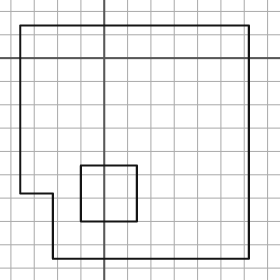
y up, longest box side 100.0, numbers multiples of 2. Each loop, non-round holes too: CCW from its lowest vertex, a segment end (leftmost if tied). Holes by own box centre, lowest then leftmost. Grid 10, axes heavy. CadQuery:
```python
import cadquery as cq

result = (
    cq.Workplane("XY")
    .moveTo(-22.0, -86.0)
    .lineTo(62.0, -86.0)
    .lineTo(62.0, 14.0)
    .lineTo(-36.0, 14.0)
    .lineTo(-36.0, -58.0)
    .lineTo(-22.0, -58.0)
    .close()
    .moveTo(-10.0, -70.0)
    .lineTo(14.0, -70.0)
    .lineTo(14.0, -46.0)
    .lineTo(-10.0, -46.0)
    .close()
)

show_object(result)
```